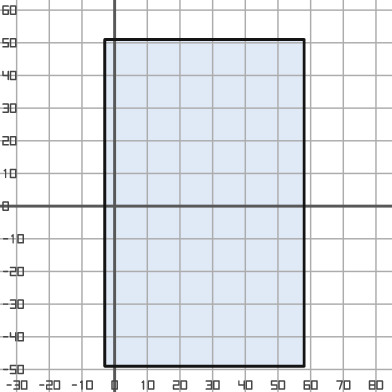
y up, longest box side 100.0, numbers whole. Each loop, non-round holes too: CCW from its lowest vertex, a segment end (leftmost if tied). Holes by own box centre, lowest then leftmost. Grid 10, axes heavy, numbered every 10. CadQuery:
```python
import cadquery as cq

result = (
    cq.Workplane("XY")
    .moveTo(-3.0, -49.0)
    .lineTo(58.0, -49.0)
    .lineTo(58.0, 51.0)
    .lineTo(-3.0, 51.0)
    .close()
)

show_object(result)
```